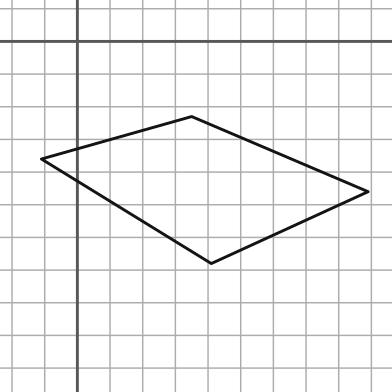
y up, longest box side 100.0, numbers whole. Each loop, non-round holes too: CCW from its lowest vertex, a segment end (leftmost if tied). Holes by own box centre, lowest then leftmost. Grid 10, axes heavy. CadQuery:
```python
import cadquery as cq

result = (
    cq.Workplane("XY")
    .moveTo(41.0, -68.0)
    .lineTo(89.0, -46.0)
    .lineTo(35.0, -23.0)
    .lineTo(-11.0, -36.0)
    .close()
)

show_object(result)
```